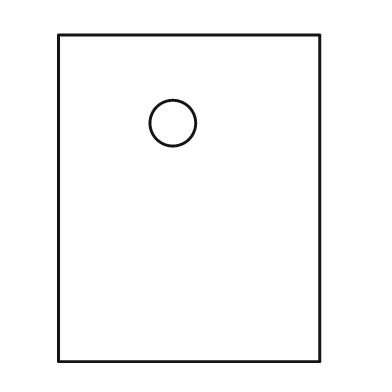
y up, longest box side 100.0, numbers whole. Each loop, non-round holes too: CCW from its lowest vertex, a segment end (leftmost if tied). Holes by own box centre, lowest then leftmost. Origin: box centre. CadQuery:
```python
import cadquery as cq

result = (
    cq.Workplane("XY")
    .moveTo(-40.0, -50.0)
    .lineTo(40.0, -50.0)
    .lineTo(40.0, 50.0)
    .lineTo(-40.0, 50.0)
    .close()
    .moveTo(-5.0, 23.0)
    .circle(7.0)
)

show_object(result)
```